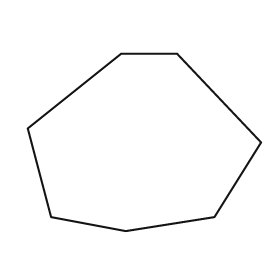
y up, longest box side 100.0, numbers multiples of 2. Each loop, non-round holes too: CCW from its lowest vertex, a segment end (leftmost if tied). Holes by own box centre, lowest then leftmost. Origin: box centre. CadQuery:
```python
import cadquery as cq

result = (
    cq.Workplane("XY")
    .moveTo(-8.0, -38.0)
    .lineTo(30.0, -32.0)
    .lineTo(50.0, 0.0)
    .lineTo(14.0, 38.0)
    .lineTo(-10.0, 38.0)
    .lineTo(-50.0, 6.0)
    .lineTo(-40.0, -32.0)
    .close()
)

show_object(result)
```